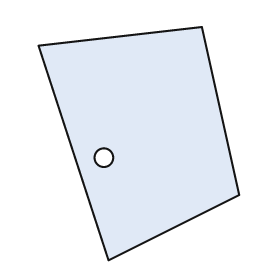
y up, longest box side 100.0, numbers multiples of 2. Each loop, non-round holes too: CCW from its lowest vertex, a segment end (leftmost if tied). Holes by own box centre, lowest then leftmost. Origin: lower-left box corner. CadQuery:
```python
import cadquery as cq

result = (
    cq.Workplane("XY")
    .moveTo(30.0, 0.0)
    .lineTo(86.0, 28.0)
    .lineTo(70.0, 100.0)
    .lineTo(0.0, 92.0)
    .close()
    .moveTo(28.0, 44.0)
    .circle(4.0)
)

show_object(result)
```